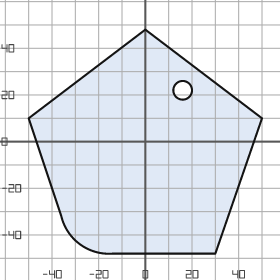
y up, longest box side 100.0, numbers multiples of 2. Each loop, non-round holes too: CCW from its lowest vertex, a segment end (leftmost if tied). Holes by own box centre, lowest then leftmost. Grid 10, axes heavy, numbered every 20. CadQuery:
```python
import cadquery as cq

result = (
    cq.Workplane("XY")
    .moveTo(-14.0, -48.0)
    .lineTo(30.0, -48.0)
    .lineTo(50.0, 10.0)
    .lineTo(0.0, 48.0)
    .lineTo(-50.0, 10.0)
    .lineTo(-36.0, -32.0)
    .threePointArc((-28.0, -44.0), (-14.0, -48.0))
    .close()
    .moveTo(16.0, 22.0)
    .circle(4.0)
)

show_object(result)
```